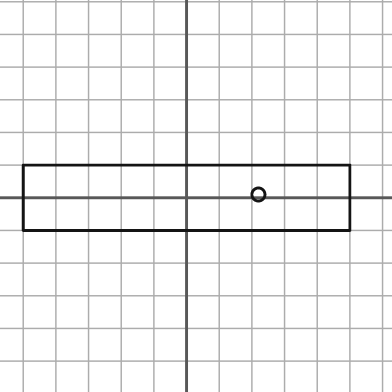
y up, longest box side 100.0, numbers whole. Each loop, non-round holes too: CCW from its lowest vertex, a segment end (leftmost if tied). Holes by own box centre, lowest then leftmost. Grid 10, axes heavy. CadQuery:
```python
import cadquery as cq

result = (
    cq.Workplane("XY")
    .moveTo(-50.0, -10.0)
    .lineTo(50.0, -10.0)
    .lineTo(50.0, 10.0)
    .lineTo(-50.0, 10.0)
    .close()
    .moveTo(22.0, 1.0)
    .circle(2.0)
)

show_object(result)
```